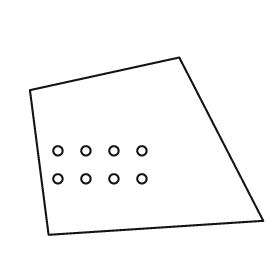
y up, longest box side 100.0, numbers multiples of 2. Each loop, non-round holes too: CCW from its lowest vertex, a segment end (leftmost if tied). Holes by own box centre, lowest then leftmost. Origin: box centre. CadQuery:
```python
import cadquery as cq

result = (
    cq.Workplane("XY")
    .moveTo(-42.0, -38.0)
    .lineTo(50.0, -32.0)
    .lineTo(14.0, 38.0)
    .lineTo(-50.0, 24.0)
    .close()
    .moveTo(-38.0, -14.0)
    .circle(2.0)
    .moveTo(-26.0, -14.0)
    .circle(2.0)
    .moveTo(-14.0, -14.0)
    .circle(2.0)
    .moveTo(-2.0, -14.0)
    .circle(2.0)
    .moveTo(-38.0, -2.0)
    .circle(2.0)
    .moveTo(-26.0, -2.0)
    .circle(2.0)
    .moveTo(-14.0, -2.0)
    .circle(2.0)
    .moveTo(-2.0, -2.0)
    .circle(2.0)
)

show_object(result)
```